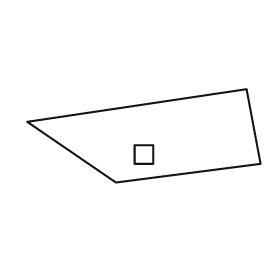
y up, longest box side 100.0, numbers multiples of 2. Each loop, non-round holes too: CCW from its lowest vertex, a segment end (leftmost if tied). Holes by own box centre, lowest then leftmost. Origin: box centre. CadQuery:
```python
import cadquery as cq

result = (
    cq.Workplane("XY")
    .moveTo(-12.0, -20.0)
    .lineTo(50.0, -12.0)
    .lineTo(44.0, 20.0)
    .lineTo(-50.0, 6.0)
    .close()
    .moveTo(-4.0, -12.0)
    .lineTo(4.0, -12.0)
    .lineTo(4.0, -4.0)
    .lineTo(-4.0, -4.0)
    .close()
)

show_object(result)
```